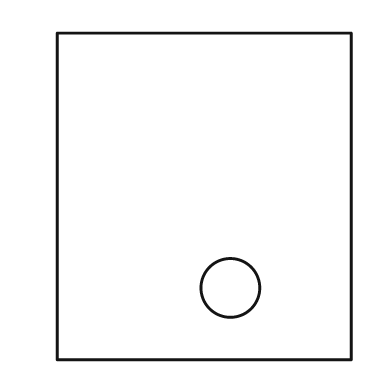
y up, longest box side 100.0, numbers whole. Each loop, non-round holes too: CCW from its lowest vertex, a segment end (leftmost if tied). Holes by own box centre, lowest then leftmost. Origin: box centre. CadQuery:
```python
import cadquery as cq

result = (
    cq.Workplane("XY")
    .moveTo(-45.0, -50.0)
    .lineTo(45.0, -50.0)
    .lineTo(45.0, 50.0)
    .lineTo(-45.0, 50.0)
    .close()
    .moveTo(8.0, -28.0)
    .circle(9.0)
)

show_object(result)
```